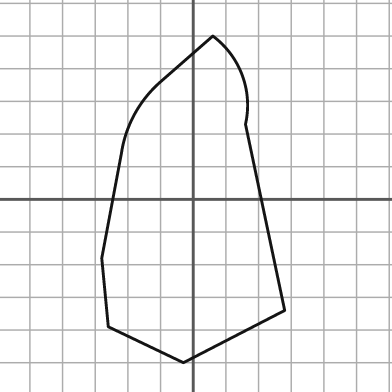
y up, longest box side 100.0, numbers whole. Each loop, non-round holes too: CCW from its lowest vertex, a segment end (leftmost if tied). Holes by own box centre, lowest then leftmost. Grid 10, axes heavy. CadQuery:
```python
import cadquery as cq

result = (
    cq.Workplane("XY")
    .moveTo(-3.0, -50.0)
    .lineTo(28.0, -34.0)
    .lineTo(16.0, 23.0)
    .threePointArc((15.0, 38.0), (6.0, 50.0))
    .lineTo(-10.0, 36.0)
    .threePointArc((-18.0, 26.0), (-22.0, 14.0))
    .lineTo(-28.0, -18.0)
    .lineTo(-26.0, -39.0)
    .close()
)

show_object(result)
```